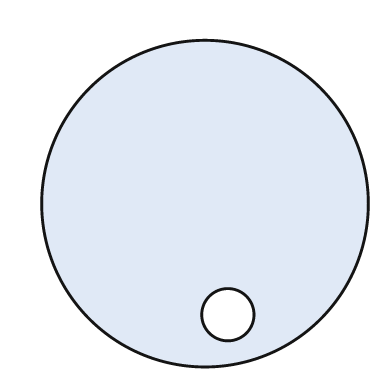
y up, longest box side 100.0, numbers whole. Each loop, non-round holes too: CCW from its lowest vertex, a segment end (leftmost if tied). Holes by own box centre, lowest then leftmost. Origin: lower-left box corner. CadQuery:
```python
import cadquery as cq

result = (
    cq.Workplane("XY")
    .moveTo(50.0, 50.0)
    .circle(50.0)
    .moveTo(57.0, 16.0)
    .circle(8.0)
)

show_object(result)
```